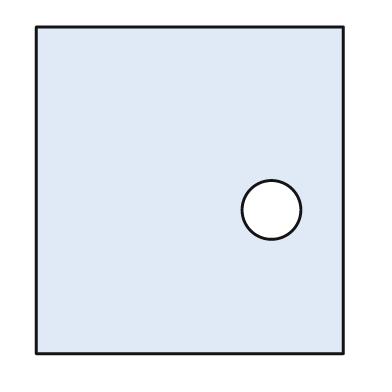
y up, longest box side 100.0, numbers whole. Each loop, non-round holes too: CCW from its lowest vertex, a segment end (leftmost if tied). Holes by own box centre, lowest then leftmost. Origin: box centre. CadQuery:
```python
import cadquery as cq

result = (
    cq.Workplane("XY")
    .moveTo(-47.0, -50.0)
    .lineTo(47.0, -50.0)
    .lineTo(47.0, 50.0)
    .lineTo(-47.0, 50.0)
    .close()
    .moveTo(25.0, -6.0)
    .circle(9.0)
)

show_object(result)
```